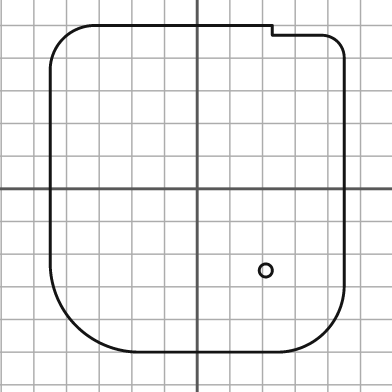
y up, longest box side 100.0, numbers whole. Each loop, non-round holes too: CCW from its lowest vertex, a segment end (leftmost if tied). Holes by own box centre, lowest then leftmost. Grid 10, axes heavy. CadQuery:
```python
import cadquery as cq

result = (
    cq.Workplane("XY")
    .moveTo(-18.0, -50.0)
    .lineTo(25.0, -50.0)
    .threePointArc((39.0, -44.0), (45.0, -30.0))
    .lineTo(45.0, 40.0)
    .threePointArc((43.0, 45.0), (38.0, 47.0))
    .lineTo(23.0, 47.0)
    .lineTo(23.0, 50.0)
    .lineTo(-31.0, 50.0)
    .threePointArc((-41.0, 46.0), (-45.0, 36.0))
    .lineTo(-45.0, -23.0)
    .threePointArc((-37.0, -42.0), (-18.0, -50.0))
    .close()
    .moveTo(21.0, -25.0)
    .circle(2.0)
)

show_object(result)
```